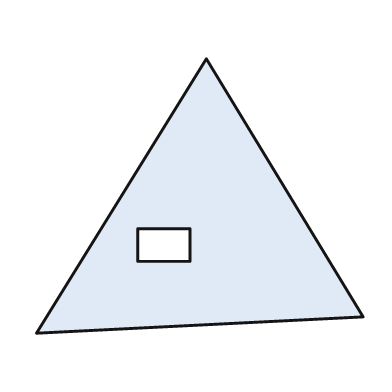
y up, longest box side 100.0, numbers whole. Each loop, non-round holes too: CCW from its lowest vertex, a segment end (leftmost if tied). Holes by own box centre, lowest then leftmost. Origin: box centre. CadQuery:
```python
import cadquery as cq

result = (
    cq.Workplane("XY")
    .moveTo(-50.0, -42.0)
    .lineTo(50.0, -37.0)
    .lineTo(2.0, 42.0)
    .close()
    .moveTo(-19.0, -20.0)
    .lineTo(-3.0, -20.0)
    .lineTo(-3.0, -10.0)
    .lineTo(-19.0, -10.0)
    .close()
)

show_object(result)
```